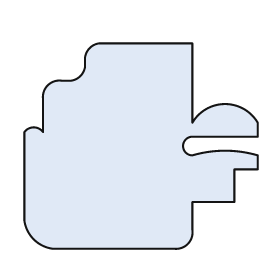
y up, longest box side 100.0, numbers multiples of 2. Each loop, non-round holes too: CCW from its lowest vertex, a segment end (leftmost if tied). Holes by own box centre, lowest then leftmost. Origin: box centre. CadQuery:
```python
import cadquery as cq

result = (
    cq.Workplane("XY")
    .moveTo(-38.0, -44.0)
    .lineTo(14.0, -44.0)
    .threePointArc((20.0, -42.0), (22.0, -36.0))
    .lineTo(22.0, -24.0)
    .lineTo(40.0, -24.0)
    .lineTo(40.0, -10.0)
    .lineTo(50.0, -10.0)
    .lineTo(50.0, -4.0)
    .threePointArc((36.0, -2.0), (22.0, -4.0))
    .threePointArc((18.0, 0.0), (22.0, 4.0))
    .lineTo(50.0, 4.0)
    .lineTo(50.0, 10.0)
    .threePointArc((36.0, 18.0), (22.0, 10.0))
    .lineTo(22.0, 44.0)
    .lineTo(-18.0, 44.0)
    .threePointArc((-22.0, 42.0), (-24.0, 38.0))
    .lineTo(-24.0, 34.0)
    .threePointArc((-26.0, 30.0), (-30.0, 28.0))
    .lineTo(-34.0, 28.0)
    .threePointArc((-40.0, 26.0), (-42.0, 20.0))
    .lineTo(-42.0, 6.0)
    .threePointArc((-46.0, 8.0), (-50.0, 6.0))
    .lineTo(-50.0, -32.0)
    .threePointArc((-46.0, -40.0), (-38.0, -44.0))
    .close()
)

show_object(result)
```